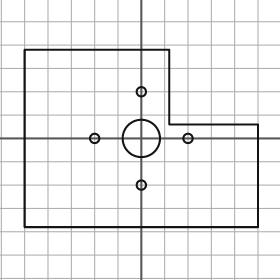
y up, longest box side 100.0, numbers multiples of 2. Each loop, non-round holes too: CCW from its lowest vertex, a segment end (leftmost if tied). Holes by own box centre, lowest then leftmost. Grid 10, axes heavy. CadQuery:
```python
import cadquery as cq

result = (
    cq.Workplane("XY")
    .moveTo(-50.0, -38.0)
    .lineTo(50.0, -38.0)
    .lineTo(50.0, 6.0)
    .lineTo(12.0, 6.0)
    .lineTo(12.0, 38.0)
    .lineTo(-50.0, 38.0)
    .close()
    .moveTo(0.0, -20.0)
    .circle(2.0)
    .moveTo(-20.0, 0.0)
    .circle(2.0)
    .moveTo(0.0, 0.0)
    .circle(8.0)
    .moveTo(20.0, 0.0)
    .circle(2.0)
    .moveTo(0.0, 20.0)
    .circle(2.0)
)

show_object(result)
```